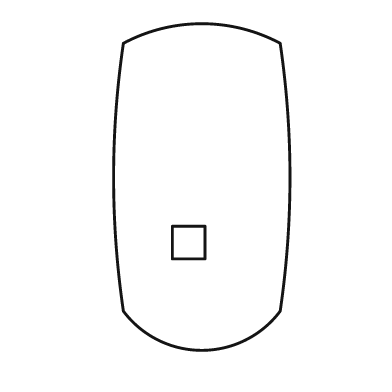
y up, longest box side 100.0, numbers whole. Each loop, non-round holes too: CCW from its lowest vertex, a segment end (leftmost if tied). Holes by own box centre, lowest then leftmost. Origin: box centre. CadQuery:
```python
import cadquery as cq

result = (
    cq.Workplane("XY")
    .moveTo(-24.0, -38.0)
    .threePointArc((0.0, -50.0), (24.0, -38.0))
    .threePointArc((27.0, 3.0), (24.0, 44.0))
    .threePointArc((0.0, 50.0), (-24.0, 44.0))
    .threePointArc((-27.0, 3.0), (-24.0, -38.0))
    .close()
    .moveTo(-9.0, -22.0)
    .lineTo(1.0, -22.0)
    .lineTo(1.0, -12.0)
    .lineTo(-9.0, -12.0)
    .close()
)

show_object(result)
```